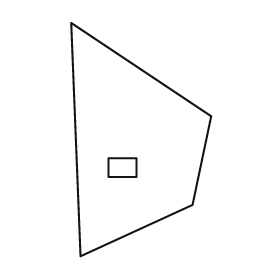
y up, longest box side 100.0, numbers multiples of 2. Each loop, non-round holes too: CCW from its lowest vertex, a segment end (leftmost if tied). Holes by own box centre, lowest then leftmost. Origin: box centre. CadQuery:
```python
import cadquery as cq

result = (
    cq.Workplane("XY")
    .moveTo(-26.0, -50.0)
    .lineTo(22.0, -28.0)
    .lineTo(30.0, 10.0)
    .lineTo(-30.0, 50.0)
    .close()
    .moveTo(-14.0, -16.0)
    .lineTo(-2.0, -16.0)
    .lineTo(-2.0, -8.0)
    .lineTo(-14.0, -8.0)
    .close()
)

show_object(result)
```